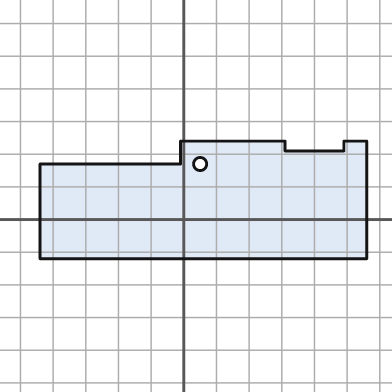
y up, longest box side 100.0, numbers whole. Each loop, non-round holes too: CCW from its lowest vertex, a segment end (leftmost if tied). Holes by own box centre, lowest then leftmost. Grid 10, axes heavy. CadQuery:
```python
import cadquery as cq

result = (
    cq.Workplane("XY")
    .moveTo(-44.0, -12.0)
    .lineTo(56.0, -12.0)
    .lineTo(56.0, 24.0)
    .lineTo(49.0, 24.0)
    .lineTo(49.0, 21.0)
    .lineTo(31.0, 21.0)
    .lineTo(31.0, 24.0)
    .lineTo(-1.0, 24.0)
    .lineTo(-1.0, 17.0)
    .lineTo(-44.0, 17.0)
    .close()
    .moveTo(5.0, 17.0)
    .circle(2.0)
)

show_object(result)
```